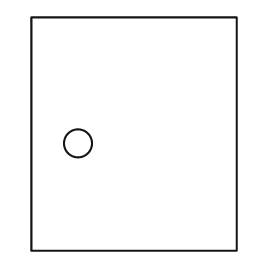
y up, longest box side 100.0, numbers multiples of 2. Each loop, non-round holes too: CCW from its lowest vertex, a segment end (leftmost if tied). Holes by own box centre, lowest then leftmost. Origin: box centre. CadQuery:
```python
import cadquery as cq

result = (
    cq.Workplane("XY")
    .moveTo(-44.0, -50.0)
    .lineTo(44.0, -50.0)
    .lineTo(44.0, 50.0)
    .lineTo(-44.0, 50.0)
    .close()
    .moveTo(-24.0, -4.0)
    .circle(6.0)
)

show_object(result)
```